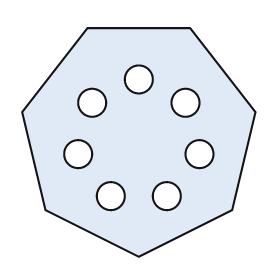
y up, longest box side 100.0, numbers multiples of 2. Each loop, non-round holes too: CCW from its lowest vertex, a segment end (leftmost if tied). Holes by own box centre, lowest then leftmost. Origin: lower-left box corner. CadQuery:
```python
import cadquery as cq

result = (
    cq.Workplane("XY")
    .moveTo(50.0, 0.0)
    .lineTo(90.0, 20.0)
    .lineTo(100.0, 62.0)
    .lineTo(72.0, 98.0)
    .lineTo(28.0, 98.0)
    .lineTo(0.0, 62.0)
    .lineTo(10.0, 20.0)
    .close()
    .moveTo(38.0, 26.0)
    .circle(6.0)
    .moveTo(62.0, 26.0)
    .circle(6.0)
    .moveTo(24.0, 44.0)
    .circle(6.0)
    .moveTo(76.0, 44.0)
    .circle(6.0)
    .moveTo(30.0, 66.0)
    .circle(6.0)
    .moveTo(70.0, 66.0)
    .circle(6.0)
    .moveTo(50.0, 76.0)
    .circle(6.0)
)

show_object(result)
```